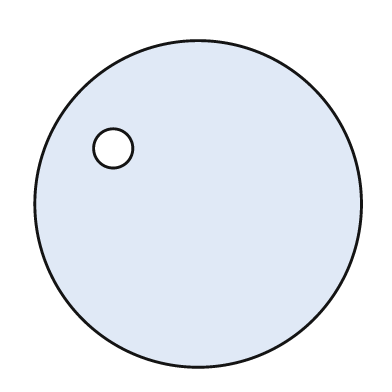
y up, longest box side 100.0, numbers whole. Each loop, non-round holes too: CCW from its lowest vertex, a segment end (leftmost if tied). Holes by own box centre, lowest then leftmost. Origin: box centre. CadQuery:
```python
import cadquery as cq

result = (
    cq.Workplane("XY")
    .moveTo(0.0, 0.0)
    .circle(50.0)
    .moveTo(-26.0, 17.0)
    .circle(6.0)
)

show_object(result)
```